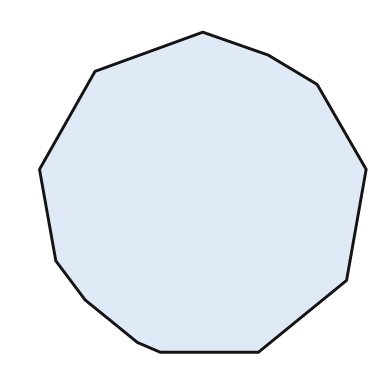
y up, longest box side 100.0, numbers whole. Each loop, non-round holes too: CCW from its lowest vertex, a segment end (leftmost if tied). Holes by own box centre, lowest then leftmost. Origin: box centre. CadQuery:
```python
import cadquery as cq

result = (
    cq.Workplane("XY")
    .moveTo(-13.0, -49.0)
    .lineTo(17.0, -49.0)
    .lineTo(44.0, -27.0)
    .lineTo(50.0, 7.0)
    .lineTo(35.0, 33.0)
    .lineTo(20.0, 42.0)
    .lineTo(0.0, 49.0)
    .lineTo(-33.0, 37.0)
    .lineTo(-50.0, 7.0)
    .lineTo(-45.0, -21.0)
    .lineTo(-36.0, -33.0)
    .lineTo(-20.0, -46.0)
    .close()
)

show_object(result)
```